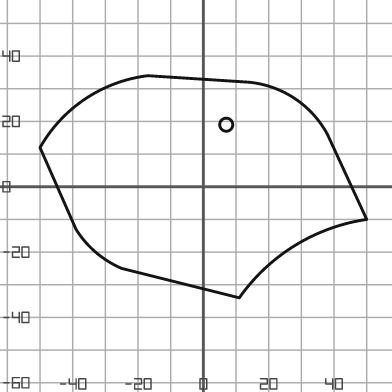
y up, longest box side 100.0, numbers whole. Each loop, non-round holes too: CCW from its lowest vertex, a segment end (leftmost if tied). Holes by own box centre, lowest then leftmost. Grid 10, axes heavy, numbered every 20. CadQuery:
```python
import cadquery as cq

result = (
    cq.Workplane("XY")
    .moveTo(11.0, -34.0)
    .threePointArc((28.0, -18.0), (50.0, -10.0))
    .lineTo(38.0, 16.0)
    .threePointArc((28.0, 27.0), (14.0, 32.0))
    .lineTo(-17.0, 34.0)
    .threePointArc((-36.0, 27.0), (-50.0, 12.0))
    .lineTo(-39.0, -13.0)
    .threePointArc((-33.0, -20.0), (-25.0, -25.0))
    .close()
    .moveTo(7.0, 19.0)
    .circle(2.0)
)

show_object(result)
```